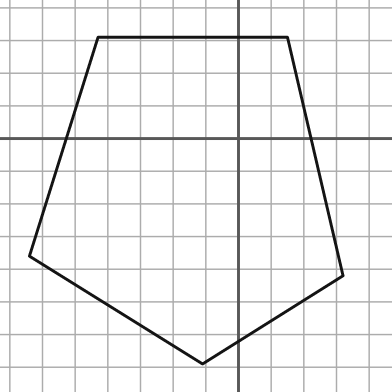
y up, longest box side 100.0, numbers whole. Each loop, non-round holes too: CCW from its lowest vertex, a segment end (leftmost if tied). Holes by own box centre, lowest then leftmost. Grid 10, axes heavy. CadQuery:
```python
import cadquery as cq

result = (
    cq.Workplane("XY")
    .moveTo(-11.0, -69.0)
    .lineTo(32.0, -42.0)
    .lineTo(15.0, 31.0)
    .lineTo(-43.0, 31.0)
    .lineTo(-64.0, -36.0)
    .close()
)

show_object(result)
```